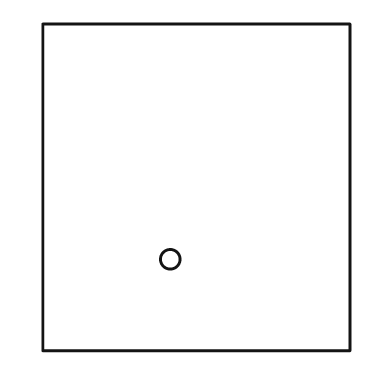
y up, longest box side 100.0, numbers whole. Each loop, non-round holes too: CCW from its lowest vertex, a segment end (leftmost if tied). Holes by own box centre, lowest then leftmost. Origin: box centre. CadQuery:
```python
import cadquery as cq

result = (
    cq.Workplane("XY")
    .moveTo(-47.0, -50.0)
    .lineTo(47.0, -50.0)
    .lineTo(47.0, 50.0)
    .lineTo(-47.0, 50.0)
    .close()
    .moveTo(-8.0, -22.0)
    .circle(3.0)
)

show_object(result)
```